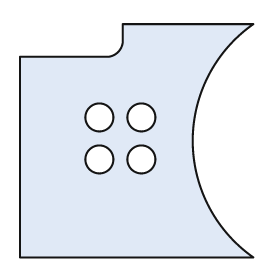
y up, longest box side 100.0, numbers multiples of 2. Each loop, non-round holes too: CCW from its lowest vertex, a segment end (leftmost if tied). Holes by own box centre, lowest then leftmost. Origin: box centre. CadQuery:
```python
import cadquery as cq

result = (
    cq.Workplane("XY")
    .moveTo(-50.0, -50.0)
    .lineTo(50.0, -50.0)
    .threePointArc((24.0, 0.0), (50.0, 50.0))
    .lineTo(-6.0, 50.0)
    .lineTo(-6.0, 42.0)
    .threePointArc((-8.0, 38.0), (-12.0, 36.0))
    .lineTo(-50.0, 36.0)
    .close()
    .moveTo(-16.0, -8.0)
    .circle(6.0)
    .moveTo(2.0, -8.0)
    .circle(6.0)
    .moveTo(-16.0, 10.0)
    .circle(6.0)
    .moveTo(2.0, 10.0)
    .circle(6.0)
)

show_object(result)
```